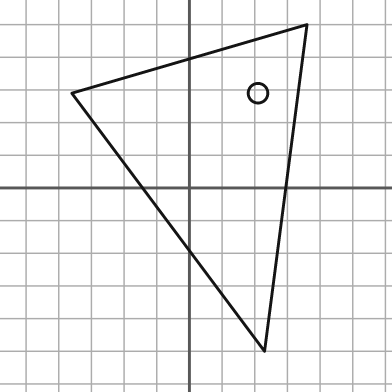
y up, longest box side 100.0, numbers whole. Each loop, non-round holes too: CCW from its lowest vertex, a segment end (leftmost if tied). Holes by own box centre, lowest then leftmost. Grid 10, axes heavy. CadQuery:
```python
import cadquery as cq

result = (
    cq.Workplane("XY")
    .moveTo(23.0, -50.0)
    .lineTo(36.0, 50.0)
    .lineTo(-36.0, 29.0)
    .close()
    .moveTo(21.0, 29.0)
    .circle(3.0)
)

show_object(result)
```